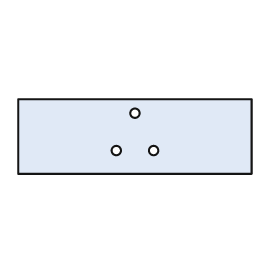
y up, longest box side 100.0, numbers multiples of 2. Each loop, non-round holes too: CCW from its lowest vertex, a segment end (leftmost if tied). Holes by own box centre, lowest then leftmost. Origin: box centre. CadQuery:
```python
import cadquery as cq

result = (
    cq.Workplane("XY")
    .moveTo(-50.0, -16.0)
    .lineTo(50.0, -16.0)
    .lineTo(50.0, 16.0)
    .lineTo(-50.0, 16.0)
    .close()
    .moveTo(-8.0, -6.0)
    .circle(2.0)
    .moveTo(8.0, -6.0)
    .circle(2.0)
    .moveTo(0.0, 10.0)
    .circle(2.0)
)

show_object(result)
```